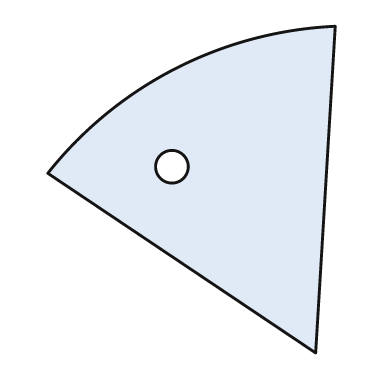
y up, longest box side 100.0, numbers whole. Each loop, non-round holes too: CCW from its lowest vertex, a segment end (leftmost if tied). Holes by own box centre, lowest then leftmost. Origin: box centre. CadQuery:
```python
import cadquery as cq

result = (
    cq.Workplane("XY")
    .moveTo(38.0, -50.0)
    .lineTo(44.0, 50.0)
    .threePointArc((-5.0, 37.0), (-44.0, 5.0))
    .close()
    .moveTo(-6.0, 7.0)
    .circle(5.0)
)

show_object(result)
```